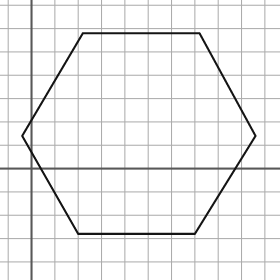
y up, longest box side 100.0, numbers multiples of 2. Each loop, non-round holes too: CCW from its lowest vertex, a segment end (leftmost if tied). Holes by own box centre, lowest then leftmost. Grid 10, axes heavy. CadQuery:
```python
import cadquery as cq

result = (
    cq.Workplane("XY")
    .moveTo(20.0, -28.0)
    .lineTo(70.0, -28.0)
    .lineTo(96.0, 14.0)
    .lineTo(72.0, 58.0)
    .lineTo(22.0, 58.0)
    .lineTo(-4.0, 14.0)
    .close()
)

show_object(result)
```